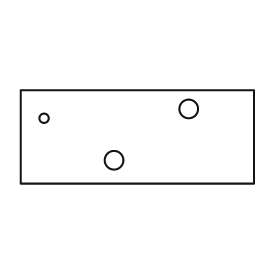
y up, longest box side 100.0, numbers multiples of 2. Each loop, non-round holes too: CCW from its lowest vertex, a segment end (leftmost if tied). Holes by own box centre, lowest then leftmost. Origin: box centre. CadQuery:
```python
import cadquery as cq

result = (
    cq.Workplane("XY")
    .moveTo(-50.0, -20.0)
    .lineTo(50.0, -20.0)
    .lineTo(50.0, 20.0)
    .lineTo(-50.0, 20.0)
    .close()
    .moveTo(-10.0, -10.0)
    .circle(4.0)
    .moveTo(-40.0, 8.0)
    .circle(2.0)
    .moveTo(22.0, 12.0)
    .circle(4.0)
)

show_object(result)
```